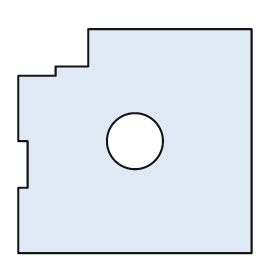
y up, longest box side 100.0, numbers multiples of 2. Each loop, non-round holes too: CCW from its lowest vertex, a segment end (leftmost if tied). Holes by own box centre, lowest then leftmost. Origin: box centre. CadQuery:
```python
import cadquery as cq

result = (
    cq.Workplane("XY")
    .moveTo(-50.0, -48.0)
    .lineTo(50.0, -48.0)
    .lineTo(50.0, 48.0)
    .lineTo(-20.0, 48.0)
    .lineTo(-20.0, 32.0)
    .lineTo(-34.0, 32.0)
    .lineTo(-34.0, 28.0)
    .lineTo(-50.0, 28.0)
    .lineTo(-50.0, 0.0)
    .lineTo(-46.0, 0.0)
    .lineTo(-46.0, -20.0)
    .lineTo(-50.0, -20.0)
    .close()
    .moveTo(0.0, 0.0)
    .circle(12.0)
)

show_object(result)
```